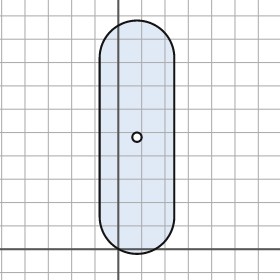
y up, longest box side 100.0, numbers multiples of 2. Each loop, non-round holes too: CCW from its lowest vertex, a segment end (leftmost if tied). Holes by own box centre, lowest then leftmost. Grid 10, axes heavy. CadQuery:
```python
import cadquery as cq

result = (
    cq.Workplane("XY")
    .moveTo(-8.0, 14.0)
    .threePointArc((8.0, -2.0), (24.0, 14.0))
    .lineTo(24.0, 82.0)
    .threePointArc((8.0, 98.0), (-8.0, 82.0))
    .close()
    .moveTo(8.0, 48.0)
    .circle(2.0)
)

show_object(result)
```